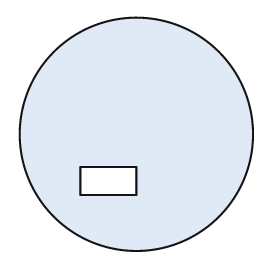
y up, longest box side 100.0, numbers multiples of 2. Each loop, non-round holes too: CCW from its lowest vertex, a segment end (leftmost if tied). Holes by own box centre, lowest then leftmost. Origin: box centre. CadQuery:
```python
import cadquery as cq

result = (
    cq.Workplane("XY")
    .moveTo(0.0, 0.0)
    .circle(50.0)
    .moveTo(-24.0, -26.0)
    .lineTo(0.0, -26.0)
    .lineTo(0.0, -14.0)
    .lineTo(-24.0, -14.0)
    .close()
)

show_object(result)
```